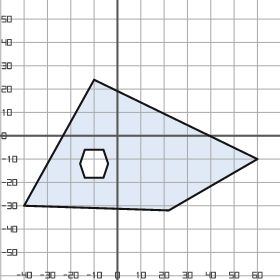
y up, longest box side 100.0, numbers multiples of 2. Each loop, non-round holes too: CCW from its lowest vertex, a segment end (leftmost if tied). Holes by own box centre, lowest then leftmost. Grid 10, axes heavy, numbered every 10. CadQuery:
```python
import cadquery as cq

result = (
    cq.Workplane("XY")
    .moveTo(22.0, -32.0)
    .lineTo(60.0, -10.0)
    .lineTo(-10.0, 24.0)
    .lineTo(-40.0, -30.0)
    .close()
    .moveTo(-14.0, -18.0)
    .lineTo(-6.0, -18.0)
    .lineTo(-4.0, -12.0)
    .lineTo(-6.0, -6.0)
    .lineTo(-14.0, -6.0)
    .lineTo(-16.0, -12.0)
    .close()
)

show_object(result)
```